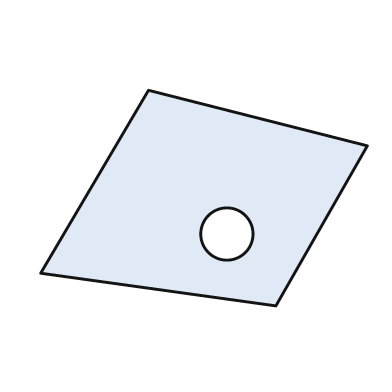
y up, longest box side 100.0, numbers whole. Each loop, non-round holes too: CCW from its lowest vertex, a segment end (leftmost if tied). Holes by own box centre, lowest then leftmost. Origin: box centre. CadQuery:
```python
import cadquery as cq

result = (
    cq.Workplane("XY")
    .moveTo(22.0, -33.0)
    .lineTo(50.0, 16.0)
    .lineTo(-17.0, 33.0)
    .lineTo(-50.0, -23.0)
    .close()
    .moveTo(7.0, -11.0)
    .circle(8.0)
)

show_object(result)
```